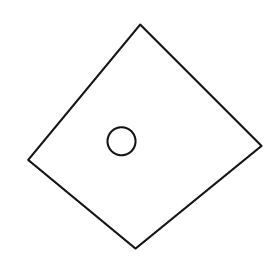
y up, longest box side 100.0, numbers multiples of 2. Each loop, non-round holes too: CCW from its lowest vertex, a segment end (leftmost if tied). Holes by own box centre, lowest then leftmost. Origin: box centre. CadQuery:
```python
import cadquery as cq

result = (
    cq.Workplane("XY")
    .moveTo(-4.0, -48.0)
    .lineTo(50.0, -4.0)
    .lineTo(-2.0, 48.0)
    .lineTo(-50.0, -10.0)
    .close()
    .moveTo(-10.0, -2.0)
    .circle(6.0)
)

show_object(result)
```